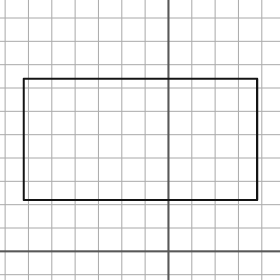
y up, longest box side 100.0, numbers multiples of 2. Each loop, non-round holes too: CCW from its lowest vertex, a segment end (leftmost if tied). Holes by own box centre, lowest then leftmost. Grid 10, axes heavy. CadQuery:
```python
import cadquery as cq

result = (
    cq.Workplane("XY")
    .moveTo(-62.0, 22.0)
    .lineTo(38.0, 22.0)
    .lineTo(38.0, 74.0)
    .lineTo(-62.0, 74.0)
    .close()
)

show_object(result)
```